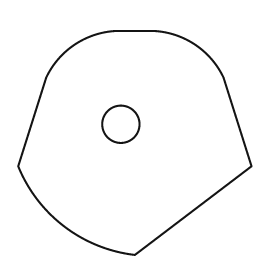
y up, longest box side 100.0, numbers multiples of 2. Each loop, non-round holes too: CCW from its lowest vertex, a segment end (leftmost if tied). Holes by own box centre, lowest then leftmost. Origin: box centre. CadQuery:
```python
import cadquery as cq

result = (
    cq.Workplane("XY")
    .moveTo(0.0, -48.0)
    .lineTo(50.0, -10.0)
    .lineTo(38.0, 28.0)
    .threePointArc((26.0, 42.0), (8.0, 48.0))
    .lineTo(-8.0, 48.0)
    .threePointArc((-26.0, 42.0), (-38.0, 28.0))
    .lineTo(-50.0, -10.0)
    .threePointArc((-30.0, -36.0), (0.0, -48.0))
    .close()
    .moveTo(-6.0, 8.0)
    .circle(8.0)
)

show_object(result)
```